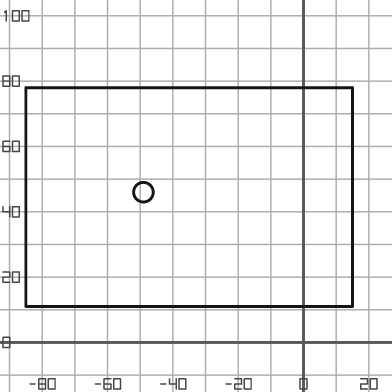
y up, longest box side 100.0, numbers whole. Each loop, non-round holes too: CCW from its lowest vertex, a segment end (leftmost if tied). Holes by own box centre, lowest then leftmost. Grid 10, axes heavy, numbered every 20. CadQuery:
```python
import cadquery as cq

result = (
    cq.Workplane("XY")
    .moveTo(-85.0, 11.0)
    .lineTo(15.0, 11.0)
    .lineTo(15.0, 78.0)
    .lineTo(-85.0, 78.0)
    .close()
    .moveTo(-49.0, 46.0)
    .circle(3.0)
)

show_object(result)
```